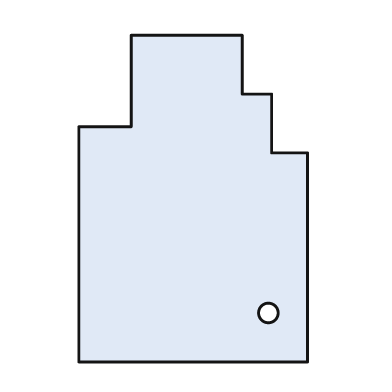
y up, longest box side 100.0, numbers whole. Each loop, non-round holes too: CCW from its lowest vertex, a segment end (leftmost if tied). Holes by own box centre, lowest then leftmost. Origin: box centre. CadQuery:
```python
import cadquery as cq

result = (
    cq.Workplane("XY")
    .moveTo(-35.0, -50.0)
    .lineTo(35.0, -50.0)
    .lineTo(35.0, 14.0)
    .lineTo(24.0, 14.0)
    .lineTo(24.0, 32.0)
    .lineTo(15.0, 32.0)
    .lineTo(15.0, 50.0)
    .lineTo(-19.0, 50.0)
    .lineTo(-19.0, 22.0)
    .lineTo(-35.0, 22.0)
    .close()
    .moveTo(23.0, -35.0)
    .circle(3.0)
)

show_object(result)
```